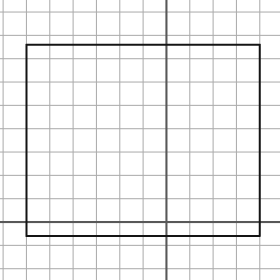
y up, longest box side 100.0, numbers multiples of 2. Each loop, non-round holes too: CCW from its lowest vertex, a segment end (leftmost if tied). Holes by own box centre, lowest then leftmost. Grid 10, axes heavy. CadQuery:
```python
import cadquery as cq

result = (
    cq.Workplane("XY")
    .moveTo(-60.0, -6.0)
    .lineTo(40.0, -6.0)
    .lineTo(40.0, 76.0)
    .lineTo(-60.0, 76.0)
    .close()
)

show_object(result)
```